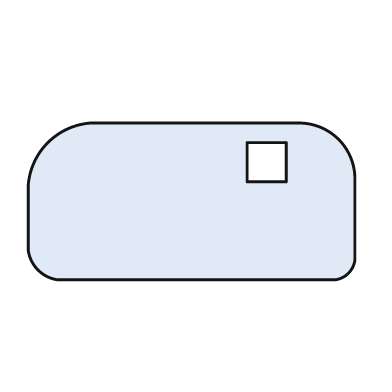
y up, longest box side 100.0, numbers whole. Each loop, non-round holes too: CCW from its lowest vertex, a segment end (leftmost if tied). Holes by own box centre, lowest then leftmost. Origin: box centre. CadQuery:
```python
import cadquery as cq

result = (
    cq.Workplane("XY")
    .moveTo(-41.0, -24.0)
    .lineTo(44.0, -24.0)
    .threePointArc((48.0, -22.0), (50.0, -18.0))
    .lineTo(50.0, 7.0)
    .threePointArc((45.0, 19.0), (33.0, 24.0))
    .lineTo(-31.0, 24.0)
    .threePointArc((-44.0, 18.0), (-50.0, 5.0))
    .lineTo(-50.0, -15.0)
    .threePointArc((-47.0, -21.0), (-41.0, -24.0))
    .close()
    .moveTo(17.0, 6.0)
    .lineTo(29.0, 6.0)
    .lineTo(29.0, 18.0)
    .lineTo(17.0, 18.0)
    .close()
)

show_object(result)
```